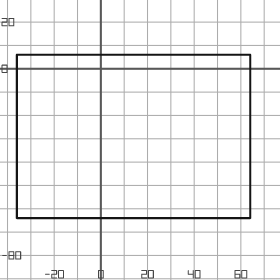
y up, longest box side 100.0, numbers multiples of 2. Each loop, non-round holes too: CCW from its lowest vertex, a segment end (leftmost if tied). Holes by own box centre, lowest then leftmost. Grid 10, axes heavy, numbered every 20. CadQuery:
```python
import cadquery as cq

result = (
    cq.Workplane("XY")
    .moveTo(-36.0, -64.0)
    .lineTo(64.0, -64.0)
    .lineTo(64.0, 6.0)
    .lineTo(-36.0, 6.0)
    .close()
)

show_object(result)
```